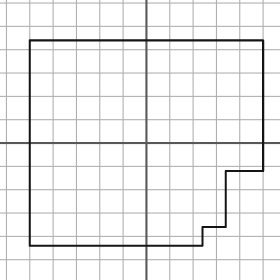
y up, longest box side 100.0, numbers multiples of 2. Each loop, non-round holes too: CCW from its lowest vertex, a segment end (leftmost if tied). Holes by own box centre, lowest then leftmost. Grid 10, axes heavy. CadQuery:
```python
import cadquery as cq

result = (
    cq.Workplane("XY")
    .moveTo(-50.0, -44.0)
    .lineTo(24.0, -44.0)
    .lineTo(24.0, -36.0)
    .lineTo(34.0, -36.0)
    .lineTo(34.0, -12.0)
    .lineTo(50.0, -12.0)
    .lineTo(50.0, 44.0)
    .lineTo(-50.0, 44.0)
    .close()
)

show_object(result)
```